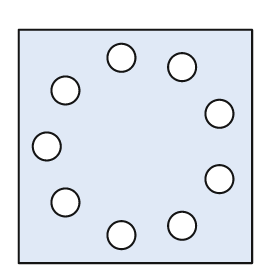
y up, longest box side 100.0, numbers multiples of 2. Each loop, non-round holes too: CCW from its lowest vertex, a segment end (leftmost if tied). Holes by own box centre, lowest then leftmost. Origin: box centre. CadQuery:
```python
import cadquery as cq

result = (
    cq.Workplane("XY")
    .moveTo(-50.0, -50.0)
    .lineTo(50.0, -50.0)
    .lineTo(50.0, 50.0)
    .lineTo(-50.0, 50.0)
    .close()
    .moveTo(-6.0, -38.0)
    .circle(6.0)
    .moveTo(20.0, -34.0)
    .circle(6.0)
    .moveTo(-30.0, -24.0)
    .circle(6.0)
    .moveTo(36.0, -14.0)
    .circle(6.0)
    .moveTo(-38.0, 0.0)
    .circle(6.0)
    .moveTo(36.0, 14.0)
    .circle(6.0)
    .moveTo(-30.0, 24.0)
    .circle(6.0)
    .moveTo(20.0, 34.0)
    .circle(6.0)
    .moveTo(-6.0, 38.0)
    .circle(6.0)
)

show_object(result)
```